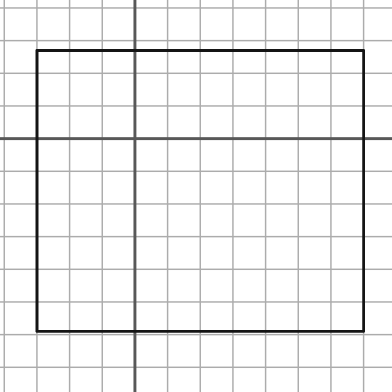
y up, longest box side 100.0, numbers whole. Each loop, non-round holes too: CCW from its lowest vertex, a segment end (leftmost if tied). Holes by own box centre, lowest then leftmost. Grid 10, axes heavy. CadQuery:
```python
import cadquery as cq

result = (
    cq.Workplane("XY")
    .moveTo(-30.0, -59.0)
    .lineTo(70.0, -59.0)
    .lineTo(70.0, 27.0)
    .lineTo(-30.0, 27.0)
    .close()
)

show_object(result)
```